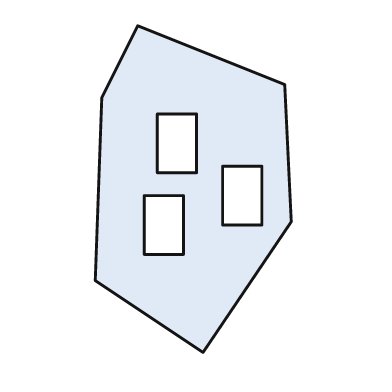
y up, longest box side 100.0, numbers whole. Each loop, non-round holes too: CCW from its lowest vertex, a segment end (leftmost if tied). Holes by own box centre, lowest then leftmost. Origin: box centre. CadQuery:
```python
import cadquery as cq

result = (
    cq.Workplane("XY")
    .moveTo(3.0, -50.0)
    .lineTo(30.0, -10.0)
    .lineTo(28.0, 32.0)
    .lineTo(-17.0, 50.0)
    .lineTo(-28.0, 28.0)
    .lineTo(-30.0, -28.0)
    .close()
    .moveTo(-15.0, -20.0)
    .lineTo(-3.0, -20.0)
    .lineTo(-3.0, -2.0)
    .lineTo(-15.0, -2.0)
    .close()
    .moveTo(9.0, -11.0)
    .lineTo(21.0, -11.0)
    .lineTo(21.0, 7.0)
    .lineTo(9.0, 7.0)
    .close()
    .moveTo(-11.0, 5.0)
    .lineTo(1.0, 5.0)
    .lineTo(1.0, 23.0)
    .lineTo(-11.0, 23.0)
    .close()
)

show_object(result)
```